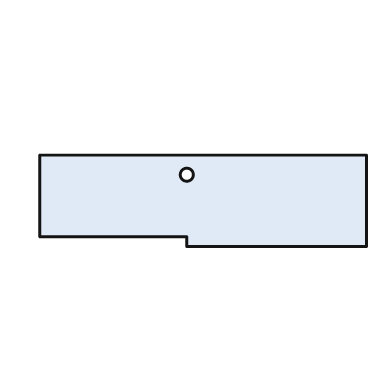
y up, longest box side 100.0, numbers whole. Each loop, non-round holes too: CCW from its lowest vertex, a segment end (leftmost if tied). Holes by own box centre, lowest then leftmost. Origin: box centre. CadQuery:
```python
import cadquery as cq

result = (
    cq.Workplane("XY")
    .moveTo(-5.0, -14.0)
    .lineTo(50.0, -14.0)
    .lineTo(50.0, 14.0)
    .lineTo(-50.0, 14.0)
    .lineTo(-50.0, -11.0)
    .lineTo(-5.0, -11.0)
    .close()
    .moveTo(-5.0, 8.0)
    .circle(2.0)
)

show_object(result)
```